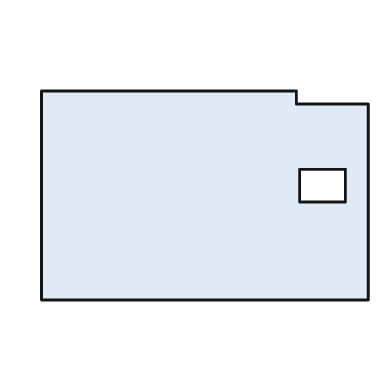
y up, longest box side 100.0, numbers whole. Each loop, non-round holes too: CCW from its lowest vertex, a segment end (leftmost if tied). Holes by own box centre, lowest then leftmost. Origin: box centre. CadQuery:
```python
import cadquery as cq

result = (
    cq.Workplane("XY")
    .moveTo(-50.0, -32.0)
    .lineTo(50.0, -32.0)
    .lineTo(50.0, 28.0)
    .lineTo(28.0, 28.0)
    .lineTo(28.0, 32.0)
    .lineTo(-50.0, 32.0)
    .close()
    .moveTo(29.0, -2.0)
    .lineTo(43.0, -2.0)
    .lineTo(43.0, 8.0)
    .lineTo(29.0, 8.0)
    .close()
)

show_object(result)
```